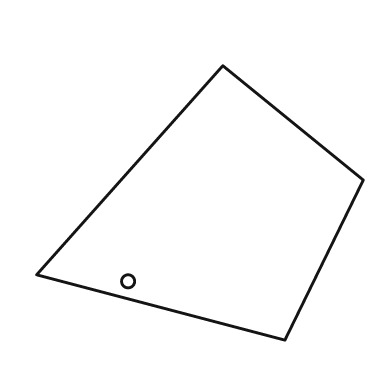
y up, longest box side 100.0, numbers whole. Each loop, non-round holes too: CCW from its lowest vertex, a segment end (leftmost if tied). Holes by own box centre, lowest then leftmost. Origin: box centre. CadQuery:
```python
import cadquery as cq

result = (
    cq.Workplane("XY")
    .moveTo(26.0, -42.0)
    .lineTo(50.0, 7.0)
    .lineTo(7.0, 42.0)
    .lineTo(-50.0, -22.0)
    .close()
    .moveTo(-22.0, -24.0)
    .circle(2.0)
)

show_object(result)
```